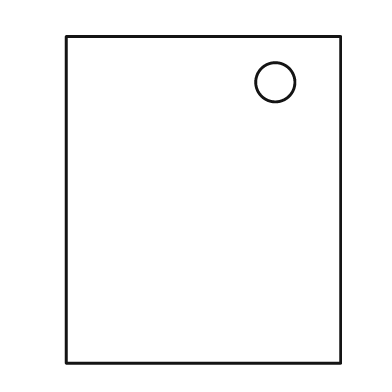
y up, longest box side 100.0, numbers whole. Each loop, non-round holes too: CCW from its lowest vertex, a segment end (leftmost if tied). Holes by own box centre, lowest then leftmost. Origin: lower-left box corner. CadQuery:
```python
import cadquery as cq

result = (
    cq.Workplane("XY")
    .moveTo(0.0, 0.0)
    .lineTo(84.0, 0.0)
    .lineTo(84.0, 100.0)
    .lineTo(0.0, 100.0)
    .close()
    .moveTo(64.0, 86.0)
    .circle(6.0)
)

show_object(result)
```